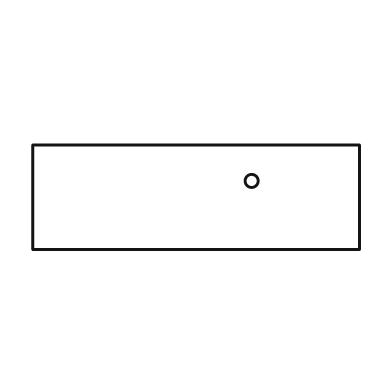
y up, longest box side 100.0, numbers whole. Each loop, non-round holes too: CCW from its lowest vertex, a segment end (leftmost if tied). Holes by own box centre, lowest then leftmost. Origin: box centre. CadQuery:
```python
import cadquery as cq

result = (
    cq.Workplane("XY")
    .moveTo(-50.0, -16.0)
    .lineTo(50.0, -16.0)
    .lineTo(50.0, 16.0)
    .lineTo(-50.0, 16.0)
    .close()
    .moveTo(17.0, 5.0)
    .circle(2.0)
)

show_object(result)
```